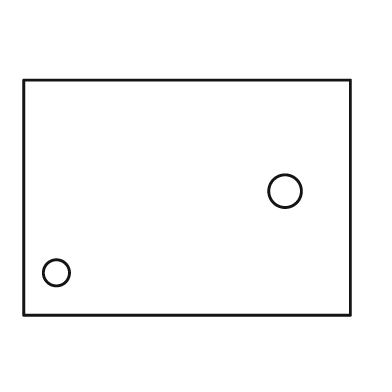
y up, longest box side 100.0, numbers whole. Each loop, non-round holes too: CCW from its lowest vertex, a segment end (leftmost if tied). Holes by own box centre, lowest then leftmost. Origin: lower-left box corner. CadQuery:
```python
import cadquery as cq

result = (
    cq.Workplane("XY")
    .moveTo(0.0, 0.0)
    .lineTo(100.0, 0.0)
    .lineTo(100.0, 72.0)
    .lineTo(0.0, 72.0)
    .close()
    .moveTo(10.0, 13.0)
    .circle(4.0)
    .moveTo(80.0, 38.0)
    .circle(5.0)
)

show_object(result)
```